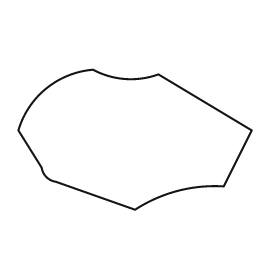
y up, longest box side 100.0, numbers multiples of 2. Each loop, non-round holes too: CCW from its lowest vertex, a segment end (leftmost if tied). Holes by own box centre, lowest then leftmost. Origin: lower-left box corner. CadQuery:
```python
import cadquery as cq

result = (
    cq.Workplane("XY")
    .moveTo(50.0, 0.0)
    .threePointArc((68.0, 8.0), (88.0, 10.0))
    .lineTo(100.0, 34.0)
    .lineTo(60.0, 58.0)
    .threePointArc((46.0, 56.0), (32.0, 60.0))
    .threePointArc((12.0, 52.0), (0.0, 34.0))
    .lineTo(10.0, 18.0)
    .threePointArc((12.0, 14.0), (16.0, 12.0))
    .close()
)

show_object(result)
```